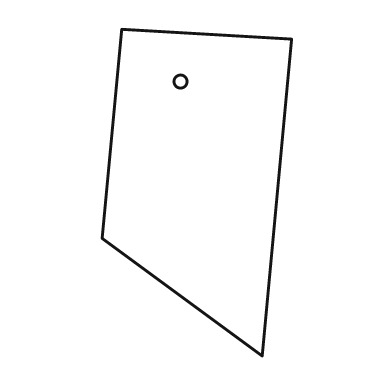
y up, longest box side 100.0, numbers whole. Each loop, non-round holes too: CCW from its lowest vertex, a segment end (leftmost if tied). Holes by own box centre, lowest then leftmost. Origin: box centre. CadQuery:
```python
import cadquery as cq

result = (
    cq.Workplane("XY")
    .moveTo(20.0, -50.0)
    .lineTo(29.0, 47.0)
    .lineTo(-23.0, 50.0)
    .lineTo(-29.0, -14.0)
    .close()
    .moveTo(-5.0, 34.0)
    .circle(2.0)
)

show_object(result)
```